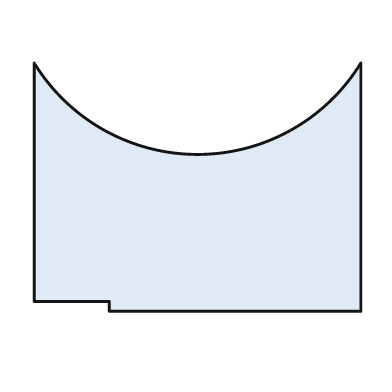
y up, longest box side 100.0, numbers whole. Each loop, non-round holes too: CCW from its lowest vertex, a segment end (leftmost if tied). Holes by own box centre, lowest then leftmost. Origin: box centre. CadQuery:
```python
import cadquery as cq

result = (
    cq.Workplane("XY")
    .moveTo(-27.0, -38.0)
    .lineTo(50.0, -38.0)
    .lineTo(50.0, 38.0)
    .threePointArc((0.0, 10.0), (-50.0, 38.0))
    .lineTo(-50.0, -35.0)
    .lineTo(-27.0, -35.0)
    .close()
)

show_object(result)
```